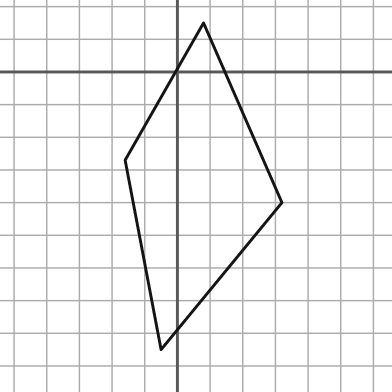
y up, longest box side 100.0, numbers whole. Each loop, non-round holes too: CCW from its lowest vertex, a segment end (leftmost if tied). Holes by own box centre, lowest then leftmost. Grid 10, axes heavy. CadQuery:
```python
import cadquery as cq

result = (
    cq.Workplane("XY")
    .moveTo(-5.0, -85.0)
    .lineTo(32.0, -40.0)
    .lineTo(8.0, 15.0)
    .lineTo(-16.0, -27.0)
    .close()
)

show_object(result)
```